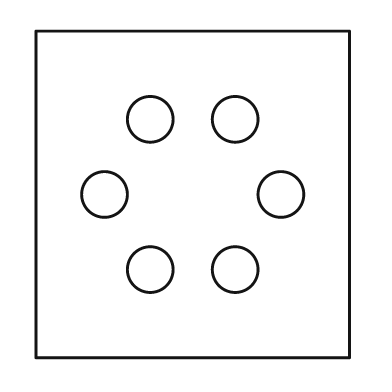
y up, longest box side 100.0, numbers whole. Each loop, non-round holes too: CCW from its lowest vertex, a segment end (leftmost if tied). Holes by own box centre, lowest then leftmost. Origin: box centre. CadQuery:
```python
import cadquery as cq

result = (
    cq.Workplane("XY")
    .moveTo(-48.0, -50.0)
    .lineTo(48.0, -50.0)
    .lineTo(48.0, 50.0)
    .lineTo(-48.0, 50.0)
    .close()
    .moveTo(-13.0, -23.0)
    .circle(7.0)
    .moveTo(13.0, -23.0)
    .circle(7.0)
    .moveTo(-27.0, 0.0)
    .circle(7.0)
    .moveTo(27.0, 0.0)
    .circle(7.0)
    .moveTo(-13.0, 23.0)
    .circle(7.0)
    .moveTo(13.0, 23.0)
    .circle(7.0)
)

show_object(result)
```